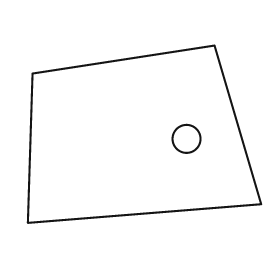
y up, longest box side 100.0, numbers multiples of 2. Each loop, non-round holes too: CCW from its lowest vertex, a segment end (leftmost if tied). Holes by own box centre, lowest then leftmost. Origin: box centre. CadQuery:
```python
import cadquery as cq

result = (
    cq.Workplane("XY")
    .moveTo(-50.0, -38.0)
    .lineTo(50.0, -30.0)
    .lineTo(30.0, 38.0)
    .lineTo(-48.0, 26.0)
    .close()
    .moveTo(18.0, -2.0)
    .circle(6.0)
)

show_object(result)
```